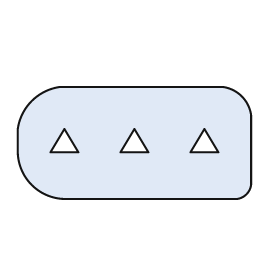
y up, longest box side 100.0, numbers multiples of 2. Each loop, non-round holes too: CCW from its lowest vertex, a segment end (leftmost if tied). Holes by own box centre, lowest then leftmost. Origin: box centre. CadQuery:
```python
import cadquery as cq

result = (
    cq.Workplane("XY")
    .moveTo(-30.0, -24.0)
    .lineTo(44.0, -24.0)
    .threePointArc((48.0, -22.0), (50.0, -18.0))
    .lineTo(50.0, 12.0)
    .threePointArc((46.0, 20.0), (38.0, 24.0))
    .lineTo(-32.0, 24.0)
    .threePointArc((-44.0, 18.0), (-50.0, 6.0))
    .lineTo(-50.0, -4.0)
    .threePointArc((-44.0, -18.0), (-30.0, -24.0))
    .close()
    .moveTo(-36.0, -4.0)
    .lineTo(-24.0, -4.0)
    .lineTo(-30.0, 6.0)
    .close()
    .moveTo(-6.0, -4.0)
    .lineTo(6.0, -4.0)
    .lineTo(0.0, 6.0)
    .close()
    .moveTo(24.0, -4.0)
    .lineTo(36.0, -4.0)
    .lineTo(30.0, 6.0)
    .close()
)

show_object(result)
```